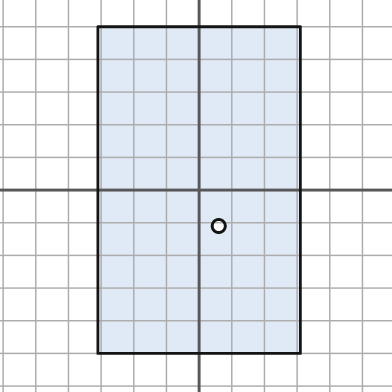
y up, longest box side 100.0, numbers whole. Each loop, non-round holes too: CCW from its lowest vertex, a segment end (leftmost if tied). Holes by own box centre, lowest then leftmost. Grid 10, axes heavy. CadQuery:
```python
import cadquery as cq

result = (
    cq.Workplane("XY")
    .moveTo(-31.0, -50.0)
    .lineTo(31.0, -50.0)
    .lineTo(31.0, 50.0)
    .lineTo(-31.0, 50.0)
    .close()
    .moveTo(6.0, -11.0)
    .circle(2.0)
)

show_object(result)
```